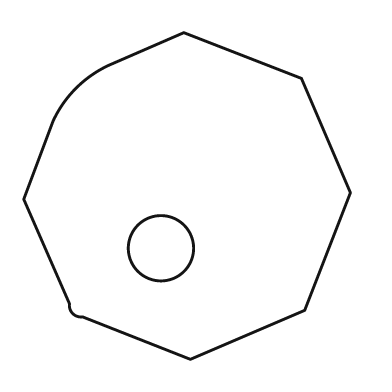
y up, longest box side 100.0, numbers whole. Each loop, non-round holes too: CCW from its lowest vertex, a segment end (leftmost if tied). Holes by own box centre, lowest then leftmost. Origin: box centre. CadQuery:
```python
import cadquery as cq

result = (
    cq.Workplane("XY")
    .moveTo(1.0, -50.0)
    .lineTo(36.0, -35.0)
    .lineTo(50.0, 1.0)
    .lineTo(35.0, 36.0)
    .lineTo(-1.0, 50.0)
    .lineTo(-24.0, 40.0)
    .threePointArc((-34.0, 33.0), (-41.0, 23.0))
    .lineTo(-50.0, -1.0)
    .lineTo(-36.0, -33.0)
    .threePointArc((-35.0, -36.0), (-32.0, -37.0))
    .close()
    .moveTo(-8.0, -16.0)
    .circle(10.0)
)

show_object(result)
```